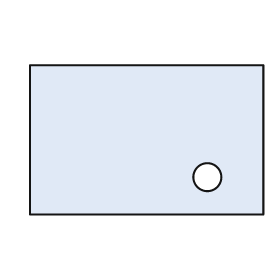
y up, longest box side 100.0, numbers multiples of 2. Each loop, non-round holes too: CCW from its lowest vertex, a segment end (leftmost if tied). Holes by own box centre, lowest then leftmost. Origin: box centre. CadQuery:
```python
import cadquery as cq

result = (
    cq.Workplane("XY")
    .moveTo(-50.0, -32.0)
    .lineTo(50.0, -32.0)
    .lineTo(50.0, 32.0)
    .lineTo(-50.0, 32.0)
    .close()
    .moveTo(26.0, -16.0)
    .circle(6.0)
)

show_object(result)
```